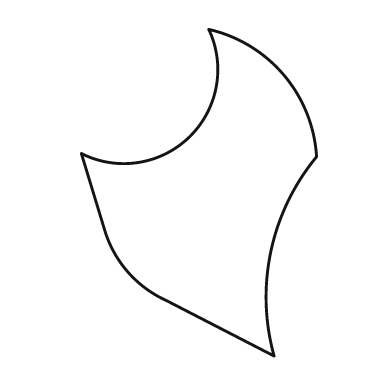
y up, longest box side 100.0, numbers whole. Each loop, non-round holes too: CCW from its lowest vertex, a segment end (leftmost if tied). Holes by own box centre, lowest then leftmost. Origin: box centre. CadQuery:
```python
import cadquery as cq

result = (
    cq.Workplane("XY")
    .moveTo(23.0, -50.0)
    .threePointArc((22.0, -18.0), (36.0, 11.0))
    .threePointArc((26.0, 36.0), (3.0, 50.0))
    .threePointArc((-3.0, 17.0), (-36.0, 12.0))
    .lineTo(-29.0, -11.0)
    .threePointArc((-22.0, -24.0), (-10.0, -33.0))
    .close()
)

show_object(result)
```